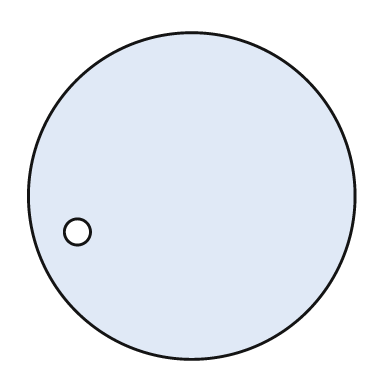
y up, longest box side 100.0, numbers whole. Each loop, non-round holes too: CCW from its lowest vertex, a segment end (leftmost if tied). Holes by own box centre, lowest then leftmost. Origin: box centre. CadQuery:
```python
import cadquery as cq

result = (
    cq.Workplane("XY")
    .moveTo(0.0, 0.0)
    .circle(50.0)
    .moveTo(-35.0, -11.0)
    .circle(4.0)
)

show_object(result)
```